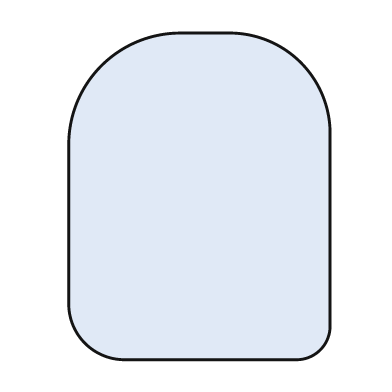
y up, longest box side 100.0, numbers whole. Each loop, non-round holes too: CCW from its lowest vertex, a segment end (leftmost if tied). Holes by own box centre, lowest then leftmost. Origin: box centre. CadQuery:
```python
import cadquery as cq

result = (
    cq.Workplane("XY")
    .moveTo(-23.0, -50.0)
    .lineTo(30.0, -50.0)
    .threePointArc((37.0, -47.0), (40.0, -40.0))
    .lineTo(40.0, 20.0)
    .threePointArc((31.0, 41.0), (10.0, 50.0))
    .lineTo(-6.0, 50.0)
    .threePointArc((-30.0, 40.0), (-40.0, 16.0))
    .lineTo(-40.0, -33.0)
    .threePointArc((-35.0, -45.0), (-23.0, -50.0))
    .close()
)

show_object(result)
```